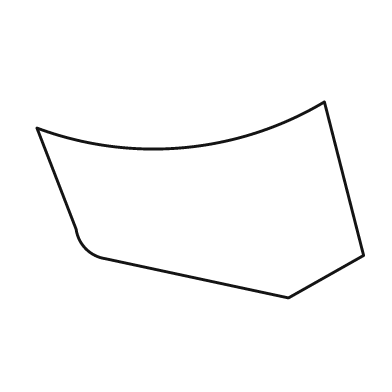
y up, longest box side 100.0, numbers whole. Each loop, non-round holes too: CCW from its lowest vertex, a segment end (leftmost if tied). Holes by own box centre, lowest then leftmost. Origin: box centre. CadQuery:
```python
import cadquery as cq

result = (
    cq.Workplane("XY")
    .moveTo(27.0, -30.0)
    .lineTo(50.0, -17.0)
    .lineTo(38.0, 30.0)
    .threePointArc((-5.0, 16.0), (-50.0, 22.0))
    .lineTo(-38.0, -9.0)
    .threePointArc((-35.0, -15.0), (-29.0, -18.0))
    .close()
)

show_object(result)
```